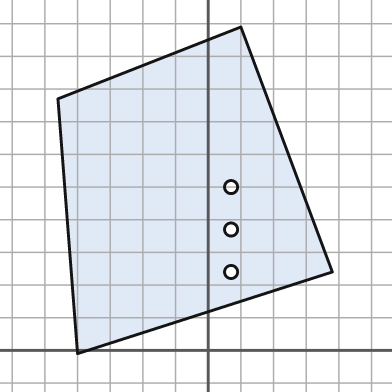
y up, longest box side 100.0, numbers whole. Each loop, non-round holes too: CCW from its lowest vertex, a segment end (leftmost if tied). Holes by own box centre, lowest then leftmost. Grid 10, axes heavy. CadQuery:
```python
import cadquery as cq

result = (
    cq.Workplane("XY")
    .moveTo(-40.0, -1.0)
    .lineTo(38.0, 24.0)
    .lineTo(10.0, 99.0)
    .lineTo(-46.0, 77.0)
    .close()
    .moveTo(7.0, 24.0)
    .circle(2.0)
    .moveTo(7.0, 37.0)
    .circle(2.0)
    .moveTo(7.0, 50.0)
    .circle(2.0)
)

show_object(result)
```